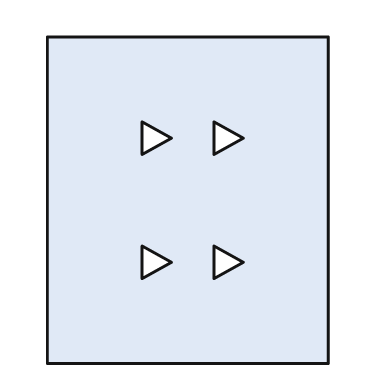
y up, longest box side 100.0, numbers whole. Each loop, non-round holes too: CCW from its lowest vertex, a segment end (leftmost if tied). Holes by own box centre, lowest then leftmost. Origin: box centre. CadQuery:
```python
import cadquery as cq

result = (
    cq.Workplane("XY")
    .moveTo(-43.0, -50.0)
    .lineTo(43.0, -50.0)
    .lineTo(43.0, 50.0)
    .lineTo(-43.0, 50.0)
    .close()
    .moveTo(-14.0, -24.0)
    .lineTo(-5.0, -19.0)
    .lineTo(-14.0, -14.0)
    .close()
    .moveTo(8.0, -24.0)
    .lineTo(17.0, -19.0)
    .lineTo(8.0, -14.0)
    .close()
    .moveTo(-14.0, 14.0)
    .lineTo(-5.0, 19.0)
    .lineTo(-14.0, 24.0)
    .close()
    .moveTo(8.0, 14.0)
    .lineTo(17.0, 19.0)
    .lineTo(8.0, 24.0)
    .close()
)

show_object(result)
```